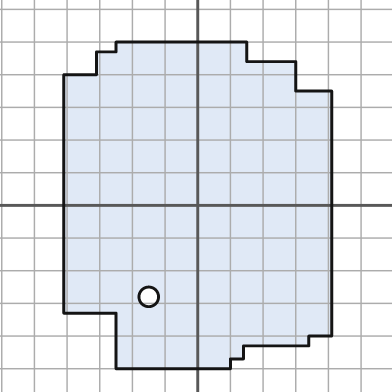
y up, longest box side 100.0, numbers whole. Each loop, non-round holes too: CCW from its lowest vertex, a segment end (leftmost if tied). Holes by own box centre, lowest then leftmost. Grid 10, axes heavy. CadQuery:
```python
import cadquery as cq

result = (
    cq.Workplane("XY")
    .moveTo(-25.0, -50.0)
    .lineTo(10.0, -50.0)
    .lineTo(10.0, -47.0)
    .lineTo(14.0, -47.0)
    .lineTo(14.0, -43.0)
    .lineTo(34.0, -43.0)
    .lineTo(34.0, -40.0)
    .lineTo(41.0, -40.0)
    .lineTo(41.0, 35.0)
    .lineTo(30.0, 35.0)
    .lineTo(30.0, 44.0)
    .lineTo(15.0, 44.0)
    .lineTo(15.0, 50.0)
    .lineTo(-25.0, 50.0)
    .lineTo(-25.0, 47.0)
    .lineTo(-31.0, 47.0)
    .lineTo(-31.0, 40.0)
    .lineTo(-41.0, 40.0)
    .lineTo(-41.0, -33.0)
    .lineTo(-25.0, -33.0)
    .close()
    .moveTo(-15.0, -28.0)
    .circle(3.0)
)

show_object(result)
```